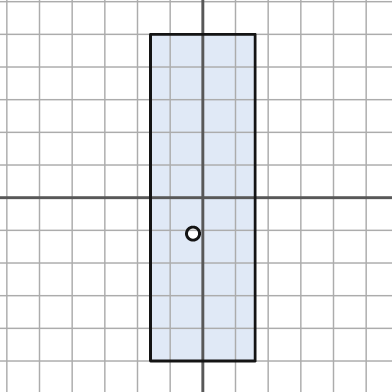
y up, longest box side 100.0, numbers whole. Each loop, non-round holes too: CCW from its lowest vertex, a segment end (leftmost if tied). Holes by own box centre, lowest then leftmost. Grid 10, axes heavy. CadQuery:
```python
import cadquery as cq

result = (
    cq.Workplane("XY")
    .moveTo(-16.0, -50.0)
    .lineTo(16.0, -50.0)
    .lineTo(16.0, 50.0)
    .lineTo(-16.0, 50.0)
    .close()
    .moveTo(-3.0, -11.0)
    .circle(2.0)
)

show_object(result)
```